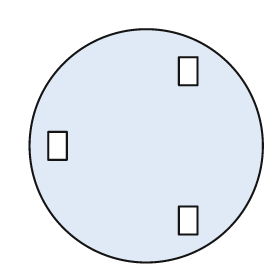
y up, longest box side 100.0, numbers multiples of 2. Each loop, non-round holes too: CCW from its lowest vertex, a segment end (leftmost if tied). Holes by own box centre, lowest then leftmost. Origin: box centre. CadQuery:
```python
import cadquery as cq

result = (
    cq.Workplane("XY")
    .moveTo(0.0, 0.0)
    .circle(50.0)
    .moveTo(14.0, -38.0)
    .lineTo(22.0, -38.0)
    .lineTo(22.0, -26.0)
    .lineTo(14.0, -26.0)
    .close()
    .moveTo(-42.0, -6.0)
    .lineTo(-34.0, -6.0)
    .lineTo(-34.0, 6.0)
    .lineTo(-42.0, 6.0)
    .close()
    .moveTo(14.0, 26.0)
    .lineTo(22.0, 26.0)
    .lineTo(22.0, 38.0)
    .lineTo(14.0, 38.0)
    .close()
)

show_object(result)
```